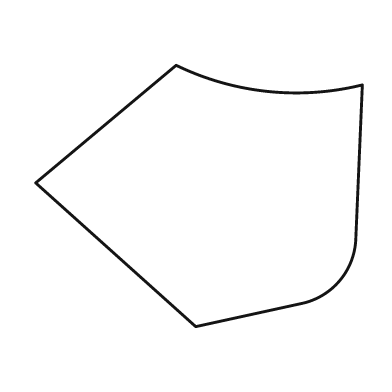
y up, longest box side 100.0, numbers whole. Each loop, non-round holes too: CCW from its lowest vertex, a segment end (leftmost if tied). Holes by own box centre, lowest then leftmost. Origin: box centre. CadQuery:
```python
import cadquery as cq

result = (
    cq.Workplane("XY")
    .moveTo(-1.0, -40.0)
    .lineTo(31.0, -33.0)
    .threePointArc((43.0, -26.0), (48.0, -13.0))
    .lineTo(50.0, 34.0)
    .threePointArc((21.0, 32.0), (-7.0, 40.0))
    .lineTo(-50.0, 4.0)
    .close()
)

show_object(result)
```